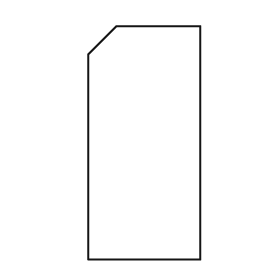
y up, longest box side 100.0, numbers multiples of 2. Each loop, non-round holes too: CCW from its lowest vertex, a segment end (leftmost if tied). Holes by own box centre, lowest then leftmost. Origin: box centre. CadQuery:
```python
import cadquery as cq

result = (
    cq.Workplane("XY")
    .moveTo(-24.0, -50.0)
    .lineTo(24.0, -50.0)
    .lineTo(24.0, 50.0)
    .lineTo(-12.0, 50.0)
    .lineTo(-24.0, 38.0)
    .close()
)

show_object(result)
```